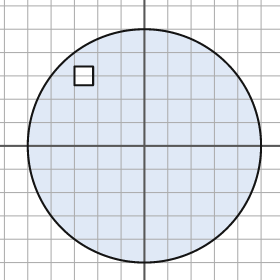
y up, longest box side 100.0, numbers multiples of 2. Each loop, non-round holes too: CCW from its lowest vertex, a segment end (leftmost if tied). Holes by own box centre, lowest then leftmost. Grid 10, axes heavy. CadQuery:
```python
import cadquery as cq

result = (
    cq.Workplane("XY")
    .moveTo(0.0, 0.0)
    .circle(50.0)
    .moveTo(-30.0, 26.0)
    .lineTo(-22.0, 26.0)
    .lineTo(-22.0, 34.0)
    .lineTo(-30.0, 34.0)
    .close()
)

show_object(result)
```